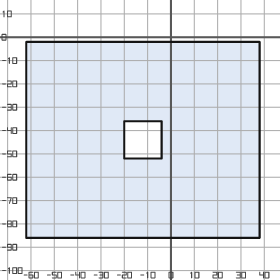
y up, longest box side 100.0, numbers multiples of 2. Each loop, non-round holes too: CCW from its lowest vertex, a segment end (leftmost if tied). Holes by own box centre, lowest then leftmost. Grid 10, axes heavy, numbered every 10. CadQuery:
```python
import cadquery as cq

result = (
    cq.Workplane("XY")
    .moveTo(-62.0, -86.0)
    .lineTo(38.0, -86.0)
    .lineTo(38.0, -2.0)
    .lineTo(-62.0, -2.0)
    .close()
    .moveTo(-20.0, -52.0)
    .lineTo(-4.0, -52.0)
    .lineTo(-4.0, -36.0)
    .lineTo(-20.0, -36.0)
    .close()
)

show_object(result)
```